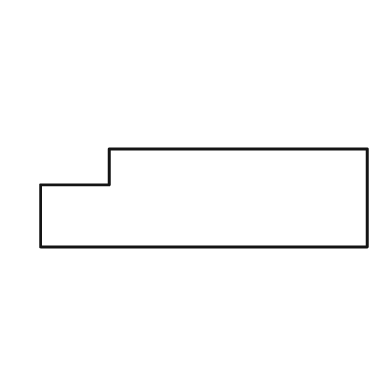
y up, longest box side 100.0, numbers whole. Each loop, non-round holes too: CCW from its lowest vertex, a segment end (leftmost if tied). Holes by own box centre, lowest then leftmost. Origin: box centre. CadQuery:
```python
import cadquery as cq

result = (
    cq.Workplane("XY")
    .moveTo(-50.0, -15.0)
    .lineTo(50.0, -15.0)
    .lineTo(50.0, 15.0)
    .lineTo(-29.0, 15.0)
    .lineTo(-29.0, 4.0)
    .lineTo(-50.0, 4.0)
    .close()
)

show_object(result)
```